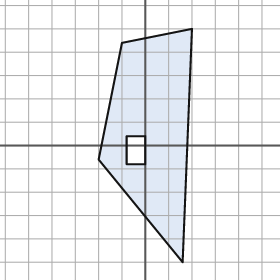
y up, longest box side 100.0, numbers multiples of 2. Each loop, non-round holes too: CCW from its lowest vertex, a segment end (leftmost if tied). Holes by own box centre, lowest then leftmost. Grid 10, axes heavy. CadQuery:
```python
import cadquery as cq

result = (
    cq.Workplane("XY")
    .moveTo(16.0, -50.0)
    .lineTo(20.0, 50.0)
    .lineTo(-10.0, 44.0)
    .lineTo(-20.0, -6.0)
    .close()
    .moveTo(-8.0, -8.0)
    .lineTo(0.0, -8.0)
    .lineTo(0.0, 4.0)
    .lineTo(-8.0, 4.0)
    .close()
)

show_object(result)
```